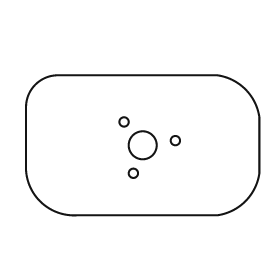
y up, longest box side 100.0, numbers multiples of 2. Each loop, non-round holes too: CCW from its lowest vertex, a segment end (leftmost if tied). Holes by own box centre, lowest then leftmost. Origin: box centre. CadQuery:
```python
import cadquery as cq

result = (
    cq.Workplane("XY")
    .moveTo(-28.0, -30.0)
    .lineTo(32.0, -30.0)
    .threePointArc((44.0, -24.0), (50.0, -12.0))
    .lineTo(50.0, 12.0)
    .threePointArc((44.0, 24.0), (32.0, 30.0))
    .lineTo(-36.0, 30.0)
    .threePointArc((-46.0, 26.0), (-50.0, 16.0))
    .lineTo(-50.0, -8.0)
    .threePointArc((-44.0, -24.0), (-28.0, -30.0))
    .close()
    .moveTo(-4.0, -12.0)
    .circle(2.0)
    .moveTo(0.0, 0.0)
    .circle(6.0)
    .moveTo(14.0, 2.0)
    .circle(2.0)
    .moveTo(-8.0, 10.0)
    .circle(2.0)
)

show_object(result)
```